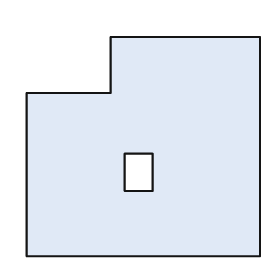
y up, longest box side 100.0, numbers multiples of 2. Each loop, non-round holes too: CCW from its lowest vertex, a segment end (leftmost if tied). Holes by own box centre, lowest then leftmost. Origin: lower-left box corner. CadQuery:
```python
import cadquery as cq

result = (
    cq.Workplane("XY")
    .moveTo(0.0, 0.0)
    .lineTo(100.0, 0.0)
    .lineTo(100.0, 94.0)
    .lineTo(36.0, 94.0)
    .lineTo(36.0, 70.0)
    .lineTo(0.0, 70.0)
    .close()
    .moveTo(42.0, 28.0)
    .lineTo(54.0, 28.0)
    .lineTo(54.0, 44.0)
    .lineTo(42.0, 44.0)
    .close()
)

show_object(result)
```